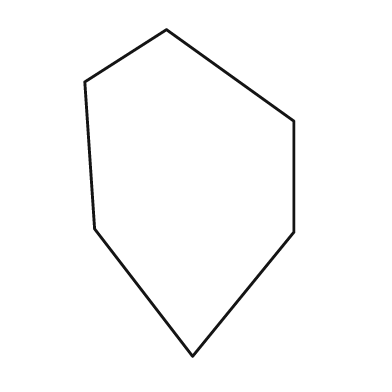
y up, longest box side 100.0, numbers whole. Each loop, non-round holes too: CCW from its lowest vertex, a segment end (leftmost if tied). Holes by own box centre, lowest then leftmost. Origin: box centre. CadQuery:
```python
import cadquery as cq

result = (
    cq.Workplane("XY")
    .moveTo(1.0, -50.0)
    .lineTo(32.0, -12.0)
    .lineTo(32.0, 22.0)
    .lineTo(-7.0, 50.0)
    .lineTo(-32.0, 34.0)
    .lineTo(-29.0, -11.0)
    .close()
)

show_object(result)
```